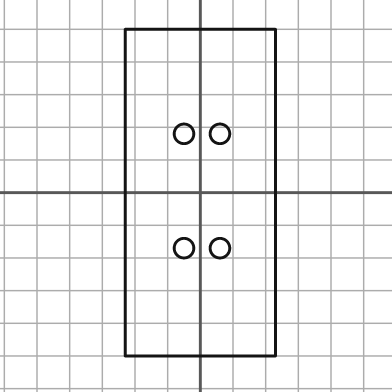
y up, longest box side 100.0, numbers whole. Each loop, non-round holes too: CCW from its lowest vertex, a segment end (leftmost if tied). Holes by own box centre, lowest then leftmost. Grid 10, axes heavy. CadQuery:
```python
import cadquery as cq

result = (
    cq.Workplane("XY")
    .moveTo(-23.0, -50.0)
    .lineTo(23.0, -50.0)
    .lineTo(23.0, 50.0)
    .lineTo(-23.0, 50.0)
    .close()
    .moveTo(-5.0, -17.0)
    .circle(3.0)
    .moveTo(6.0, -17.0)
    .circle(3.0)
    .moveTo(-5.0, 18.0)
    .circle(3.0)
    .moveTo(6.0, 18.0)
    .circle(3.0)
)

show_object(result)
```